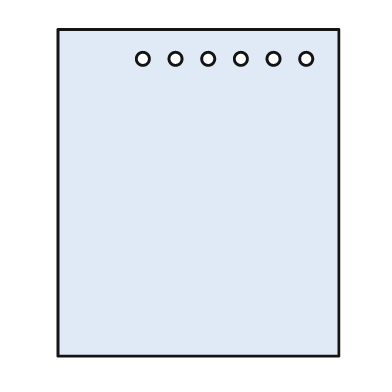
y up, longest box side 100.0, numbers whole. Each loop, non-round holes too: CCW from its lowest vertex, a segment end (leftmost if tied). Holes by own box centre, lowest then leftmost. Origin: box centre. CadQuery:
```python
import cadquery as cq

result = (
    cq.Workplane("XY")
    .moveTo(-43.0, -50.0)
    .lineTo(43.0, -50.0)
    .lineTo(43.0, 50.0)
    .lineTo(-43.0, 50.0)
    .close()
    .moveTo(-17.0, 41.0)
    .circle(2.0)
    .moveTo(-7.0, 41.0)
    .circle(2.0)
    .moveTo(3.0, 41.0)
    .circle(2.0)
    .moveTo(13.0, 41.0)
    .circle(2.0)
    .moveTo(23.0, 41.0)
    .circle(2.0)
    .moveTo(33.0, 41.0)
    .circle(2.0)
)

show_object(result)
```